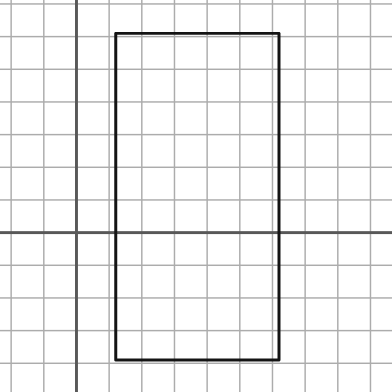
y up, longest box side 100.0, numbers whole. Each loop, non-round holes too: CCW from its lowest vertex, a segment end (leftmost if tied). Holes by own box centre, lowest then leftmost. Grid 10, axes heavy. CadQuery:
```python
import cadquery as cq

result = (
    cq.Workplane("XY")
    .moveTo(12.0, -39.0)
    .lineTo(62.0, -39.0)
    .lineTo(62.0, 61.0)
    .lineTo(12.0, 61.0)
    .close()
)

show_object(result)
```